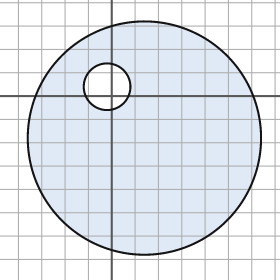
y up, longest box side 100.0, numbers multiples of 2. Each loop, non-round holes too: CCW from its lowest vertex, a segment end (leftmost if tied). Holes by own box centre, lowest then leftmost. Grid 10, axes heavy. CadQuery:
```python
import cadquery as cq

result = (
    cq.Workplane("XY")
    .moveTo(14.0, -18.0)
    .circle(50.0)
    .moveTo(-2.0, 4.0)
    .circle(10.0)
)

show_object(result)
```